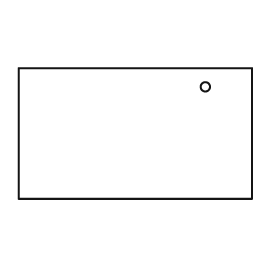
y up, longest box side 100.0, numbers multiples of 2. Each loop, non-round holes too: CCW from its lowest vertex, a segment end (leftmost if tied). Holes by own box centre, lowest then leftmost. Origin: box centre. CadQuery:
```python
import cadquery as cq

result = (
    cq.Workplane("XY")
    .moveTo(-50.0, -28.0)
    .lineTo(50.0, -28.0)
    .lineTo(50.0, 28.0)
    .lineTo(-50.0, 28.0)
    .close()
    .moveTo(30.0, 20.0)
    .circle(2.0)
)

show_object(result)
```